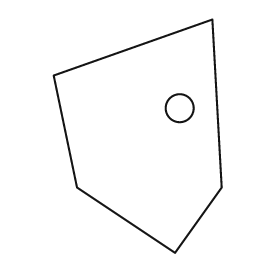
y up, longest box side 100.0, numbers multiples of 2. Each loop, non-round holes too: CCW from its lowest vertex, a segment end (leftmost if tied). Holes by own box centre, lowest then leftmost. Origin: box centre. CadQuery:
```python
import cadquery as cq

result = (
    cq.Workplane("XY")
    .moveTo(16.0, -50.0)
    .lineTo(36.0, -22.0)
    .lineTo(32.0, 50.0)
    .lineTo(-36.0, 26.0)
    .lineTo(-26.0, -22.0)
    .close()
    .moveTo(18.0, 12.0)
    .circle(6.0)
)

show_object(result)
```